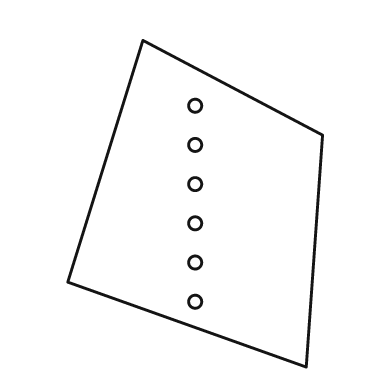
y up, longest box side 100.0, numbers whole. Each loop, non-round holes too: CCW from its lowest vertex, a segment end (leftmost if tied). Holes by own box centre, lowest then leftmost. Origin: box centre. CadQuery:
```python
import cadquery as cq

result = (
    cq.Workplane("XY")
    .moveTo(34.0, -50.0)
    .lineTo(39.0, 21.0)
    .lineTo(-16.0, 50.0)
    .lineTo(-39.0, -24.0)
    .close()
    .moveTo(0.0, -30.0)
    .circle(2.0)
    .moveTo(0.0, -18.0)
    .circle(2.0)
    .moveTo(0.0, -6.0)
    .circle(2.0)
    .moveTo(0.0, 6.0)
    .circle(2.0)
    .moveTo(0.0, 18.0)
    .circle(2.0)
    .moveTo(0.0, 30.0)
    .circle(2.0)
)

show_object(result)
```